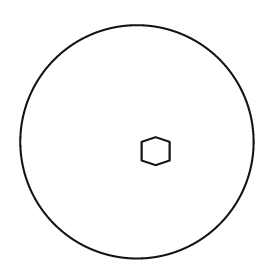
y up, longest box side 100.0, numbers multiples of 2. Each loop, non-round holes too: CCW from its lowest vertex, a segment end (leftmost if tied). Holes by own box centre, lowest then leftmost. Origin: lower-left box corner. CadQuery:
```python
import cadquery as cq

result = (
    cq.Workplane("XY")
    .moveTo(50.0, 50.0)
    .circle(50.0)
    .moveTo(58.0, 40.0)
    .lineTo(64.0, 42.0)
    .lineTo(64.0, 50.0)
    .lineTo(58.0, 52.0)
    .lineTo(52.0, 50.0)
    .lineTo(52.0, 42.0)
    .close()
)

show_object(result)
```